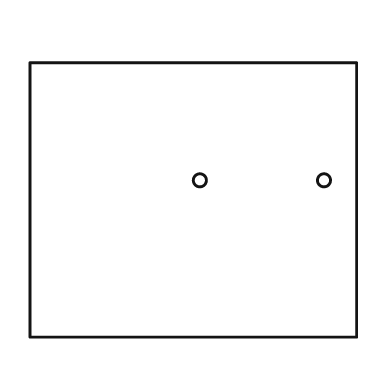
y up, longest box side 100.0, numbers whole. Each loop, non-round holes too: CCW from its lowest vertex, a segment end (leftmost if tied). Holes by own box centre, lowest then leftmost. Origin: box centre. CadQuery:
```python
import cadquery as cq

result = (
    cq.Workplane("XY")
    .moveTo(-50.0, -42.0)
    .lineTo(50.0, -42.0)
    .lineTo(50.0, 42.0)
    .lineTo(-50.0, 42.0)
    .close()
    .moveTo(2.0, 6.0)
    .circle(2.0)
    .moveTo(40.0, 6.0)
    .circle(2.0)
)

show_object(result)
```